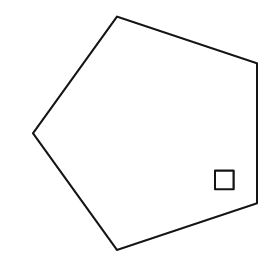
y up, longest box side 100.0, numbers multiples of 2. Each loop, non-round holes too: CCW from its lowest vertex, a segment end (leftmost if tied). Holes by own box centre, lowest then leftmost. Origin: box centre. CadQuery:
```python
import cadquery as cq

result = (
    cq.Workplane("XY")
    .moveTo(-12.0, -50.0)
    .lineTo(48.0, -30.0)
    .lineTo(48.0, 30.0)
    .lineTo(-12.0, 50.0)
    .lineTo(-48.0, 0.0)
    .close()
    .moveTo(30.0, -24.0)
    .lineTo(38.0, -24.0)
    .lineTo(38.0, -16.0)
    .lineTo(30.0, -16.0)
    .close()
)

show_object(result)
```